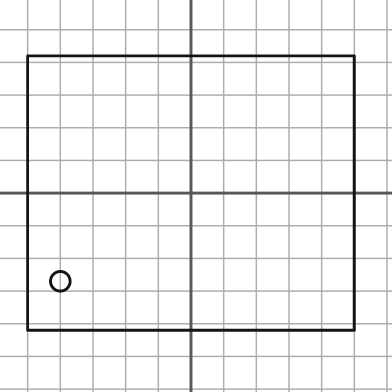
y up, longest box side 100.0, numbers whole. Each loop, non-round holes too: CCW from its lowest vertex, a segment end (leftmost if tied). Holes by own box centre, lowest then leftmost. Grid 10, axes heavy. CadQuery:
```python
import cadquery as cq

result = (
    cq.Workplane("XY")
    .moveTo(-50.0, -42.0)
    .lineTo(50.0, -42.0)
    .lineTo(50.0, 42.0)
    .lineTo(-50.0, 42.0)
    .close()
    .moveTo(-40.0, -27.0)
    .circle(3.0)
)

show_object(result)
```